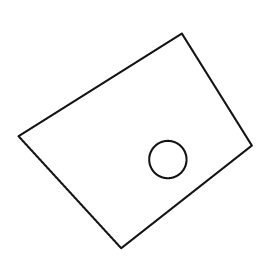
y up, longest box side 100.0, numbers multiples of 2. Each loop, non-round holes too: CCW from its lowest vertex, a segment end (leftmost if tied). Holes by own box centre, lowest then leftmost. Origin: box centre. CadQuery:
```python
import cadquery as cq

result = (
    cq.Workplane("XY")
    .moveTo(-6.0, -46.0)
    .lineTo(50.0, -2.0)
    .lineTo(20.0, 46.0)
    .lineTo(-50.0, 2.0)
    .close()
    .moveTo(14.0, -8.0)
    .circle(8.0)
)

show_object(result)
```